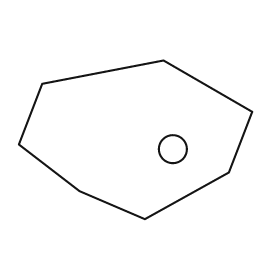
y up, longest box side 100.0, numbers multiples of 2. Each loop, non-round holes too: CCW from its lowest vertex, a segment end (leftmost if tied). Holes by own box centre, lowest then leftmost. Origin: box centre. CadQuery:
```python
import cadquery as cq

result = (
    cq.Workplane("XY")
    .moveTo(4.0, -34.0)
    .lineTo(40.0, -14.0)
    .lineTo(50.0, 12.0)
    .lineTo(12.0, 34.0)
    .lineTo(-40.0, 24.0)
    .lineTo(-50.0, -2.0)
    .lineTo(-24.0, -22.0)
    .close()
    .moveTo(16.0, -4.0)
    .circle(6.0)
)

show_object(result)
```